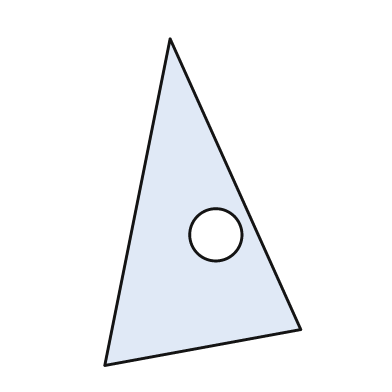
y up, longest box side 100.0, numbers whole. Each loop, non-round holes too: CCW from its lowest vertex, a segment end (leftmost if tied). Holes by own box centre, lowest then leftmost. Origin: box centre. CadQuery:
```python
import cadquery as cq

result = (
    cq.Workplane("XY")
    .moveTo(-30.0, -50.0)
    .lineTo(30.0, -39.0)
    .lineTo(-10.0, 50.0)
    .close()
    .moveTo(4.0, -10.0)
    .circle(8.0)
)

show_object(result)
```